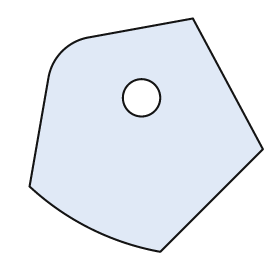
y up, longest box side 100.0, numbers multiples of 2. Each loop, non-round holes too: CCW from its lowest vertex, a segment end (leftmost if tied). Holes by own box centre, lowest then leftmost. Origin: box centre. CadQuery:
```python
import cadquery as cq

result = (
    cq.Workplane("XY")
    .moveTo(6.0, -50.0)
    .lineTo(50.0, -6.0)
    .lineTo(20.0, 50.0)
    .lineTo(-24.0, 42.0)
    .threePointArc((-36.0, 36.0), (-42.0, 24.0))
    .lineTo(-50.0, -22.0)
    .threePointArc((-24.0, -40.0), (6.0, -50.0))
    .close()
    .moveTo(-2.0, 16.0)
    .circle(8.0)
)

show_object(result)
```